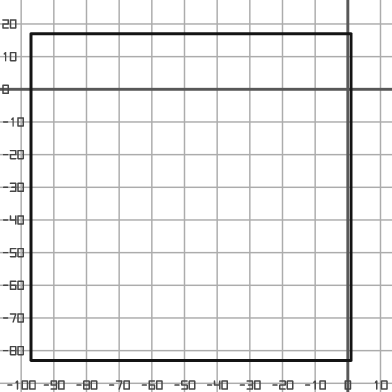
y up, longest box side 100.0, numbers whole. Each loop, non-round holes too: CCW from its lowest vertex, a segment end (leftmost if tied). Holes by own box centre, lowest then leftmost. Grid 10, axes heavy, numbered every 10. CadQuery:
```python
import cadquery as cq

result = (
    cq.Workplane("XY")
    .moveTo(-97.0, -83.0)
    .lineTo(1.0, -83.0)
    .lineTo(1.0, 17.0)
    .lineTo(-97.0, 17.0)
    .close()
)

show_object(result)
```